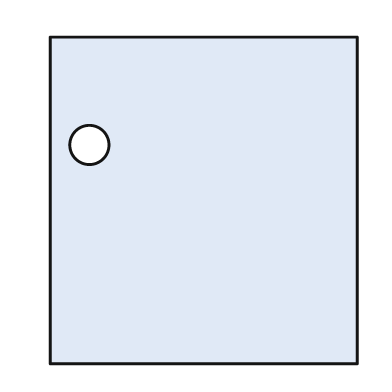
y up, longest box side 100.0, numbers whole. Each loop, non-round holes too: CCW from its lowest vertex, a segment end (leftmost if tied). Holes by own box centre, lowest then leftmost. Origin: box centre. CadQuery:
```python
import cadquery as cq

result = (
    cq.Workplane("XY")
    .moveTo(-47.0, -50.0)
    .lineTo(47.0, -50.0)
    .lineTo(47.0, 50.0)
    .lineTo(-47.0, 50.0)
    .close()
    .moveTo(-35.0, 17.0)
    .circle(6.0)
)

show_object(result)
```